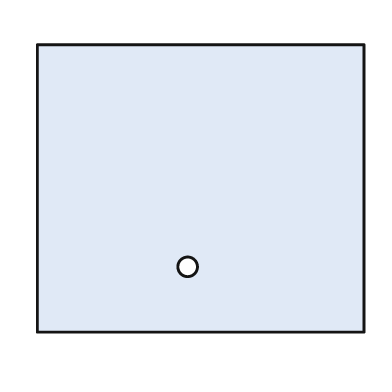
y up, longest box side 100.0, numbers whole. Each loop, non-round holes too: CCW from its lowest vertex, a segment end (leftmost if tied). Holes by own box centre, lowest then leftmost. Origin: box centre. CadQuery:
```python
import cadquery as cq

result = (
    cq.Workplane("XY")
    .moveTo(-50.0, -44.0)
    .lineTo(50.0, -44.0)
    .lineTo(50.0, 44.0)
    .lineTo(-50.0, 44.0)
    .close()
    .moveTo(-4.0, -24.0)
    .circle(3.0)
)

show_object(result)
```